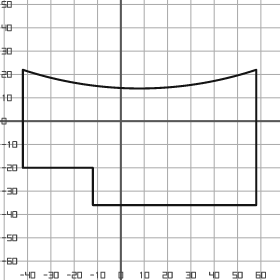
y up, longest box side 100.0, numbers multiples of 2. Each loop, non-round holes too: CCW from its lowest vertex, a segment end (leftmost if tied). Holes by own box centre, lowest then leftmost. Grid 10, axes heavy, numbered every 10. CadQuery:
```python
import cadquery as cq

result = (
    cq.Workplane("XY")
    .moveTo(-12.0, -36.0)
    .lineTo(58.0, -36.0)
    .lineTo(58.0, 22.0)
    .threePointArc((8.0, 14.0), (-42.0, 22.0))
    .lineTo(-42.0, -20.0)
    .lineTo(-12.0, -20.0)
    .close()
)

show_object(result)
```